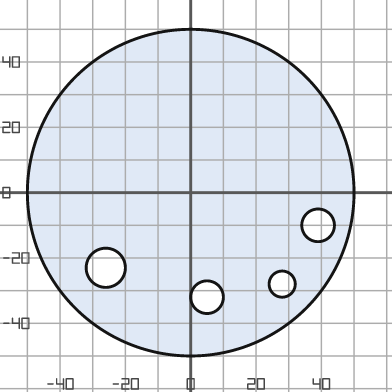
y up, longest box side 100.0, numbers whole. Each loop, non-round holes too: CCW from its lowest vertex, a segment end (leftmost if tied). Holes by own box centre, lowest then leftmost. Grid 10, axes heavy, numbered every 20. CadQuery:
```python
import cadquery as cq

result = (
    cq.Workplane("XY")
    .moveTo(0.0, 0.0)
    .circle(50.0)
    .moveTo(5.0, -32.0)
    .circle(5.0)
    .moveTo(28.0, -28.0)
    .circle(4.0)
    .moveTo(-26.0, -23.0)
    .circle(6.0)
    .moveTo(39.0, -10.0)
    .circle(5.0)
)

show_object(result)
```